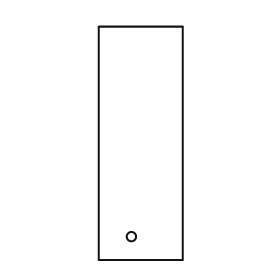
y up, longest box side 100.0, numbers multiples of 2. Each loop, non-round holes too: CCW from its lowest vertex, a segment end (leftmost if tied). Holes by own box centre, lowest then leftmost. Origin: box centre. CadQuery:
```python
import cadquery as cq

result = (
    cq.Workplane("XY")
    .moveTo(-18.0, -50.0)
    .lineTo(18.0, -50.0)
    .lineTo(18.0, 50.0)
    .lineTo(-18.0, 50.0)
    .close()
    .moveTo(-4.0, -40.0)
    .circle(2.0)
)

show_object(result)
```